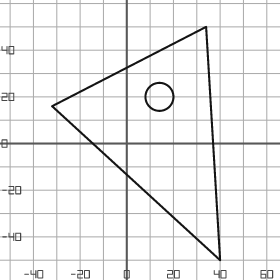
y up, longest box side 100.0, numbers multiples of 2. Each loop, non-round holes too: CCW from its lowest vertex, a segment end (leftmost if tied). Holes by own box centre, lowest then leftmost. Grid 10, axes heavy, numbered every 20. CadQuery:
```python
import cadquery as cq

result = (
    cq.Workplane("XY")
    .moveTo(40.0, -50.0)
    .lineTo(34.0, 50.0)
    .lineTo(-32.0, 16.0)
    .close()
    .moveTo(14.0, 20.0)
    .circle(6.0)
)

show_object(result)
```